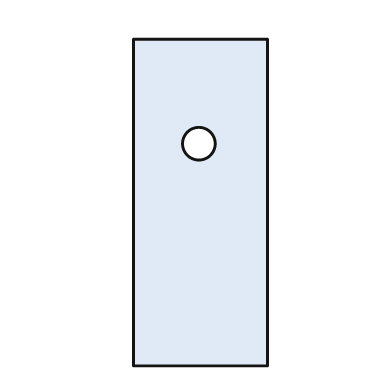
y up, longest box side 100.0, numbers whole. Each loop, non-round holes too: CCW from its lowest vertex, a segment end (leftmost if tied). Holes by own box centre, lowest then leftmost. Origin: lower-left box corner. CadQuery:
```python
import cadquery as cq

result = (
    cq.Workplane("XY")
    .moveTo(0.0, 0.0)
    .lineTo(41.0, 0.0)
    .lineTo(41.0, 100.0)
    .lineTo(0.0, 100.0)
    .close()
    .moveTo(20.0, 68.0)
    .circle(5.0)
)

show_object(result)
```